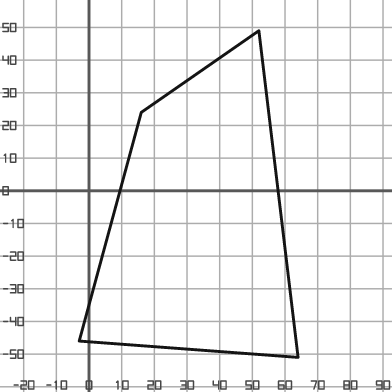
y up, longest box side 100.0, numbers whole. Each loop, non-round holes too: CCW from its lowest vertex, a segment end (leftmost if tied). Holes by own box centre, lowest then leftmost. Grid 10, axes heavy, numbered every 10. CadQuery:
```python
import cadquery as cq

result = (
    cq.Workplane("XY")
    .moveTo(64.0, -51.0)
    .lineTo(52.0, 49.0)
    .lineTo(16.0, 24.0)
    .lineTo(-3.0, -46.0)
    .close()
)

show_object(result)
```